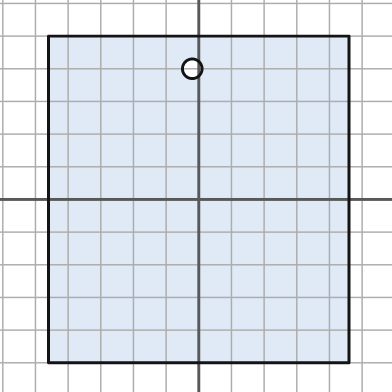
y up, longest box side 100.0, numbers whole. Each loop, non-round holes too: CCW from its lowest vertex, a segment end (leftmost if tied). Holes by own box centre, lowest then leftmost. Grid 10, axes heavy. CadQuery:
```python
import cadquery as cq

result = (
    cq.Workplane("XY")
    .moveTo(-46.0, -50.0)
    .lineTo(46.0, -50.0)
    .lineTo(46.0, 50.0)
    .lineTo(-46.0, 50.0)
    .close()
    .moveTo(-2.0, 40.0)
    .circle(3.0)
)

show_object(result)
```